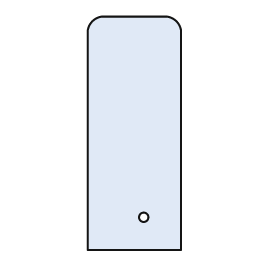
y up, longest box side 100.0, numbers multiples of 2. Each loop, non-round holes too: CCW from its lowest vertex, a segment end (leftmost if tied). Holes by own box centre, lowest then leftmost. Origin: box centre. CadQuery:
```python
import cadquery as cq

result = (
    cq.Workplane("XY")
    .moveTo(-20.0, -50.0)
    .lineTo(20.0, -50.0)
    .lineTo(20.0, 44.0)
    .threePointArc((18.0, 48.0), (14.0, 50.0))
    .lineTo(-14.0, 50.0)
    .threePointArc((-18.0, 48.0), (-20.0, 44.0))
    .close()
    .moveTo(4.0, -36.0)
    .circle(2.0)
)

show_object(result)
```